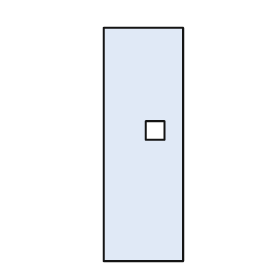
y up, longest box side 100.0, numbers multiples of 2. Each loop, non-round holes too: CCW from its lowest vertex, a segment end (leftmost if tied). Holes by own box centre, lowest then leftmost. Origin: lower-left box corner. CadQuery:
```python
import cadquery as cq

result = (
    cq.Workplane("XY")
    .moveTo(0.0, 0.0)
    .lineTo(34.0, 0.0)
    .lineTo(34.0, 100.0)
    .lineTo(0.0, 100.0)
    .close()
    .moveTo(18.0, 52.0)
    .lineTo(26.0, 52.0)
    .lineTo(26.0, 60.0)
    .lineTo(18.0, 60.0)
    .close()
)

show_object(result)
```